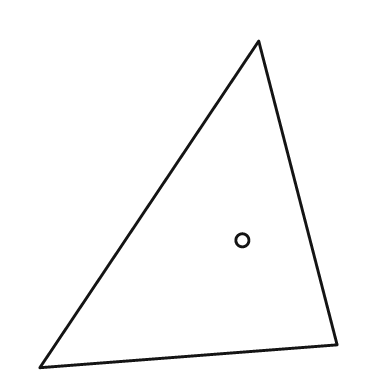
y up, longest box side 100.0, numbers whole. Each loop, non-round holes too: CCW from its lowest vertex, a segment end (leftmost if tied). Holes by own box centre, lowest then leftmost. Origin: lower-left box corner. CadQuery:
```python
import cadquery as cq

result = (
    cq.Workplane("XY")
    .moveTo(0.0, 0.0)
    .lineTo(91.0, 7.0)
    .lineTo(67.0, 100.0)
    .close()
    .moveTo(62.0, 39.0)
    .circle(2.0)
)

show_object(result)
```